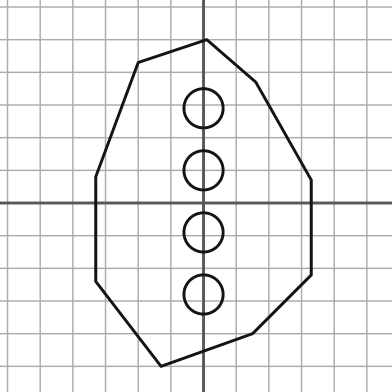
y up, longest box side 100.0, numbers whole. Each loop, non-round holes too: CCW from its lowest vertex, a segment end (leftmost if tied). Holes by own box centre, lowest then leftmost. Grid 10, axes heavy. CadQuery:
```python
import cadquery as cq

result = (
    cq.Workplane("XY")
    .moveTo(-13.0, -50.0)
    .lineTo(15.0, -40.0)
    .lineTo(33.0, -22.0)
    .lineTo(33.0, 7.0)
    .lineTo(16.0, 37.0)
    .lineTo(1.0, 50.0)
    .lineTo(-20.0, 43.0)
    .lineTo(-33.0, 8.0)
    .lineTo(-33.0, -24.0)
    .close()
    .moveTo(0.0, -28.0)
    .circle(6.0)
    .moveTo(0.0, -9.0)
    .circle(6.0)
    .moveTo(0.0, 10.0)
    .circle(6.0)
    .moveTo(0.0, 29.0)
    .circle(6.0)
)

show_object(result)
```